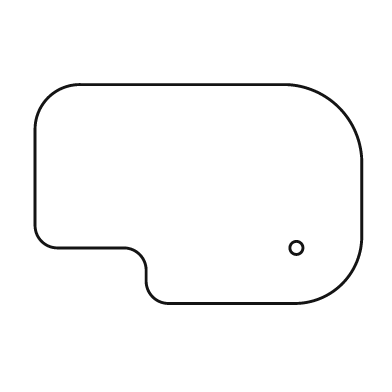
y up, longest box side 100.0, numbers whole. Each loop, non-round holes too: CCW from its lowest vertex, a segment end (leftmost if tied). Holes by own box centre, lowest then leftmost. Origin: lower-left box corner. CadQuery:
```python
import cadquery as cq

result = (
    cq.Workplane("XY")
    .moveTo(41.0, 0.0)
    .lineTo(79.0, 0.0)
    .threePointArc((94.0, 6.0), (100.0, 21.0))
    .lineTo(100.0, 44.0)
    .threePointArc((93.0, 60.0), (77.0, 67.0))
    .lineTo(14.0, 67.0)
    .threePointArc((4.0, 63.0), (0.0, 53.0))
    .lineTo(0.0, 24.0)
    .threePointArc((2.0, 19.0), (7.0, 17.0))
    .lineTo(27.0, 17.0)
    .threePointArc((32.0, 15.0), (34.0, 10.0))
    .lineTo(34.0, 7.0)
    .threePointArc((36.0, 2.0), (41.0, 0.0))
    .close()
    .moveTo(80.0, 17.0)
    .circle(2.0)
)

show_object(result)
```